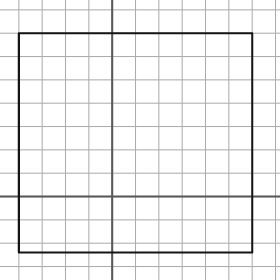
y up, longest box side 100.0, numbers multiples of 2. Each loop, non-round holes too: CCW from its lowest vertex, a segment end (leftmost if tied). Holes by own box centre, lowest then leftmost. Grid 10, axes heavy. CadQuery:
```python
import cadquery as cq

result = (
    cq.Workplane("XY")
    .moveTo(-40.0, -24.0)
    .lineTo(60.0, -24.0)
    .lineTo(60.0, 70.0)
    .lineTo(-40.0, 70.0)
    .close()
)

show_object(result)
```